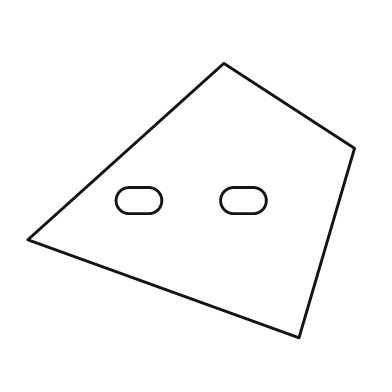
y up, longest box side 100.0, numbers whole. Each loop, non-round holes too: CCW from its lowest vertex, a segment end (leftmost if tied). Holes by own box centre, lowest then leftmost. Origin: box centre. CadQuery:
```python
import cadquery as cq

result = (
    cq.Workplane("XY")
    .moveTo(33.0, -42.0)
    .lineTo(50.0, 16.0)
    .lineTo(10.0, 42.0)
    .lineTo(-50.0, -12.0)
    .close()
    .moveTo(-19.0, -4.0)
    .lineTo(-13.0, -4.0)
    .threePointArc((-9.0, 0.0), (-13.0, 4.0))
    .lineTo(-19.0, 4.0)
    .threePointArc((-23.0, 0.0), (-19.0, -4.0))
    .close()
    .moveTo(13.0, -4.0)
    .lineTo(19.0, -4.0)
    .threePointArc((23.0, 0.0), (19.0, 4.0))
    .lineTo(13.0, 4.0)
    .threePointArc((9.0, 0.0), (13.0, -4.0))
    .close()
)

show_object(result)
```